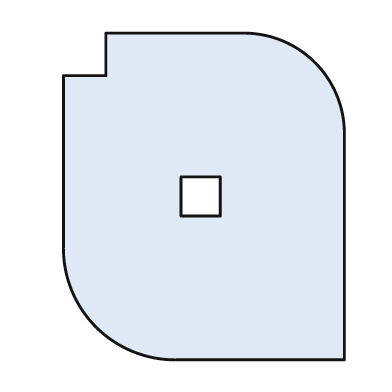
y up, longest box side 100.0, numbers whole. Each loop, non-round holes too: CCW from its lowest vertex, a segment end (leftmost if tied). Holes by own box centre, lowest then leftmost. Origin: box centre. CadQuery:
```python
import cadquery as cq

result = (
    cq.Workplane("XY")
    .moveTo(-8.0, -50.0)
    .lineTo(43.0, -50.0)
    .lineTo(43.0, 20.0)
    .threePointArc((34.0, 41.0), (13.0, 50.0))
    .lineTo(-30.0, 50.0)
    .lineTo(-30.0, 37.0)
    .lineTo(-43.0, 37.0)
    .lineTo(-43.0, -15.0)
    .threePointArc((-33.0, -40.0), (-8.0, -50.0))
    .close()
    .moveTo(-7.0, -6.0)
    .lineTo(5.0, -6.0)
    .lineTo(5.0, 6.0)
    .lineTo(-7.0, 6.0)
    .close()
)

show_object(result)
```